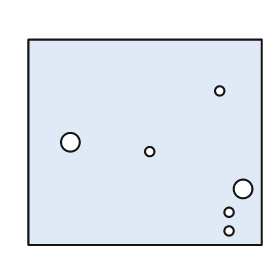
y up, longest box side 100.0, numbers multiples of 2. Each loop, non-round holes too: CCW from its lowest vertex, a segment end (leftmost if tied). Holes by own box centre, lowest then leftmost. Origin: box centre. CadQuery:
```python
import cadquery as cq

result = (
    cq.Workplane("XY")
    .moveTo(-50.0, -44.0)
    .lineTo(50.0, -44.0)
    .lineTo(50.0, 44.0)
    .lineTo(-50.0, 44.0)
    .close()
    .moveTo(36.0, -38.0)
    .circle(2.0)
    .moveTo(36.0, -30.0)
    .circle(2.0)
    .moveTo(42.0, -20.0)
    .circle(4.0)
    .moveTo(2.0, -4.0)
    .circle(2.0)
    .moveTo(-32.0, 0.0)
    .circle(4.0)
    .moveTo(32.0, 22.0)
    .circle(2.0)
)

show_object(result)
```